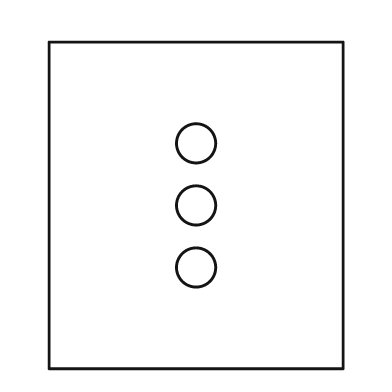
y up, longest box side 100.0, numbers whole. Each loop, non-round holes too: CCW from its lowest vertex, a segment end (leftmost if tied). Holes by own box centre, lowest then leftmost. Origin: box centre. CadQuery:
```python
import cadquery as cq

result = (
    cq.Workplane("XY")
    .moveTo(-45.0, -50.0)
    .lineTo(45.0, -50.0)
    .lineTo(45.0, 50.0)
    .lineTo(-45.0, 50.0)
    .close()
    .moveTo(0.0, -19.0)
    .circle(6.0)
    .moveTo(0.0, 0.0)
    .circle(6.0)
    .moveTo(0.0, 19.0)
    .circle(6.0)
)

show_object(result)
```